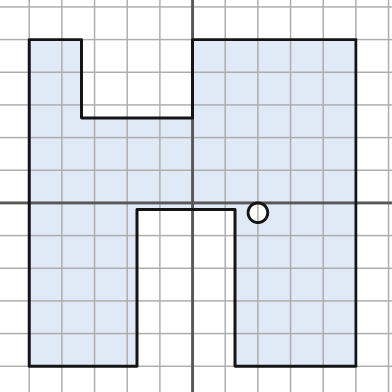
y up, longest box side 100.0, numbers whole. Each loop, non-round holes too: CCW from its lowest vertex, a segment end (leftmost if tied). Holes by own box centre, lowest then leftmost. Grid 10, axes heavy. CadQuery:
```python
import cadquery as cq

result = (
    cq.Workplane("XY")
    .moveTo(-50.0, -50.0)
    .lineTo(-17.0, -50.0)
    .lineTo(-17.0, -2.0)
    .lineTo(13.0, -2.0)
    .lineTo(13.0, -50.0)
    .lineTo(50.0, -50.0)
    .lineTo(50.0, 50.0)
    .lineTo(0.0, 50.0)
    .lineTo(0.0, 26.0)
    .lineTo(-34.0, 26.0)
    .lineTo(-34.0, 50.0)
    .lineTo(-50.0, 50.0)
    .close()
    .moveTo(20.0, -3.0)
    .circle(3.0)
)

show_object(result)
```